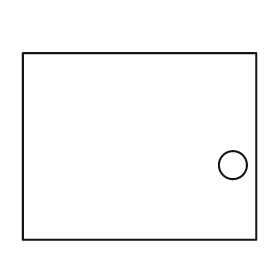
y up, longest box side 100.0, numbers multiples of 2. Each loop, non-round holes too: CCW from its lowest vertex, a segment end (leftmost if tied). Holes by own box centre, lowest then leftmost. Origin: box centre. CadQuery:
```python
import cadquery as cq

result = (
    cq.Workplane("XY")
    .moveTo(-50.0, -40.0)
    .lineTo(50.0, -40.0)
    .lineTo(50.0, 40.0)
    .lineTo(-50.0, 40.0)
    .close()
    .moveTo(40.0, -8.0)
    .circle(6.0)
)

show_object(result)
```